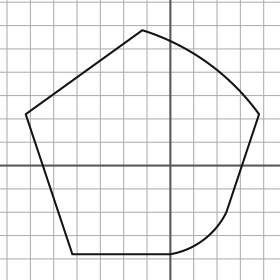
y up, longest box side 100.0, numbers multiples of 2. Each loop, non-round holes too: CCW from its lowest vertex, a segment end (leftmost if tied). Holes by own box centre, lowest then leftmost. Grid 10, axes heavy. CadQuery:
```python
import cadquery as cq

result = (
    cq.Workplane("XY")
    .moveTo(-42.0, -38.0)
    .lineTo(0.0, -38.0)
    .threePointArc((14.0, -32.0), (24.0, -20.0))
    .lineTo(38.0, 22.0)
    .threePointArc((16.0, 44.0), (-12.0, 58.0))
    .lineTo(-62.0, 22.0)
    .close()
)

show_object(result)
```